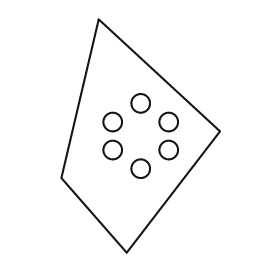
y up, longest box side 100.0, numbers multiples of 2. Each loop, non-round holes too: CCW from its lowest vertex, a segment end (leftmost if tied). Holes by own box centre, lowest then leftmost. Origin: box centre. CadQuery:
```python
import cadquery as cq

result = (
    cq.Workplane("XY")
    .moveTo(-6.0, -50.0)
    .lineTo(34.0, 2.0)
    .lineTo(-18.0, 50.0)
    .lineTo(-34.0, -18.0)
    .close()
    .moveTo(0.0, -14.0)
    .circle(4.0)
    .moveTo(-12.0, -6.0)
    .circle(4.0)
    .moveTo(12.0, -6.0)
    .circle(4.0)
    .moveTo(-12.0, 6.0)
    .circle(4.0)
    .moveTo(12.0, 6.0)
    .circle(4.0)
    .moveTo(0.0, 14.0)
    .circle(4.0)
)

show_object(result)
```